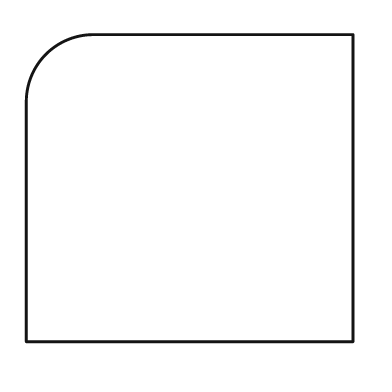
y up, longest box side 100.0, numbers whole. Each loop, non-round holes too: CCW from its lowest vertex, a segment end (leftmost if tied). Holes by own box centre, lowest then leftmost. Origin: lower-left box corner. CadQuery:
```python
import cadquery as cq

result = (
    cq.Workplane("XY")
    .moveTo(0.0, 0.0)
    .lineTo(100.0, 0.0)
    .lineTo(100.0, 94.0)
    .lineTo(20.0, 94.0)
    .threePointArc((6.0, 88.0), (0.0, 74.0))
    .close()
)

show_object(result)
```